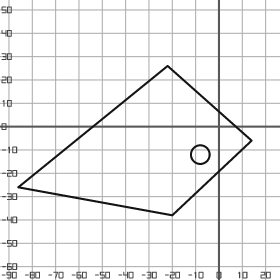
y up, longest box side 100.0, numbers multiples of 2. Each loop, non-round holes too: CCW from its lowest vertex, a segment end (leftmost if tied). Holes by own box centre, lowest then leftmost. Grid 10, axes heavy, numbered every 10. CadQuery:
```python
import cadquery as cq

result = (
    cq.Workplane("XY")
    .moveTo(-20.0, -38.0)
    .lineTo(14.0, -6.0)
    .lineTo(-22.0, 26.0)
    .lineTo(-86.0, -26.0)
    .close()
    .moveTo(-8.0, -12.0)
    .circle(4.0)
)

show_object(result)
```